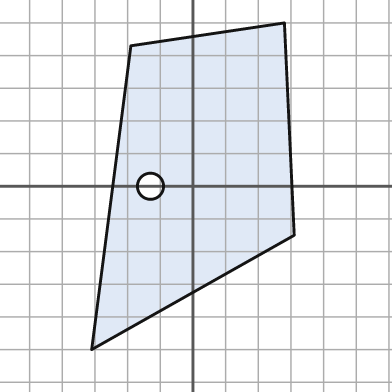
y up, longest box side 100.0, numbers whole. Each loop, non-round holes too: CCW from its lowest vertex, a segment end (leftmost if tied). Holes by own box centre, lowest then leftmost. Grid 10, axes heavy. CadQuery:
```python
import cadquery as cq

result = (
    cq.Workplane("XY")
    .moveTo(-31.0, -50.0)
    .lineTo(31.0, -15.0)
    .lineTo(28.0, 50.0)
    .lineTo(-19.0, 43.0)
    .close()
    .moveTo(-13.0, 0.0)
    .circle(4.0)
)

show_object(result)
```